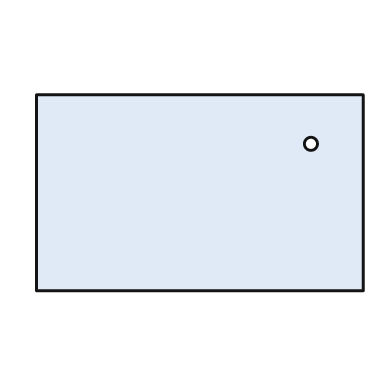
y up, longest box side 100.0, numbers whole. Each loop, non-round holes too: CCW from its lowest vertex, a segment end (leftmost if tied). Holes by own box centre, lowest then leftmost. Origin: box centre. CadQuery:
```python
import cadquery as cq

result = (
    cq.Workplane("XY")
    .moveTo(-50.0, -30.0)
    .lineTo(50.0, -30.0)
    .lineTo(50.0, 30.0)
    .lineTo(-50.0, 30.0)
    .close()
    .moveTo(34.0, 15.0)
    .circle(2.0)
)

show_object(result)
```